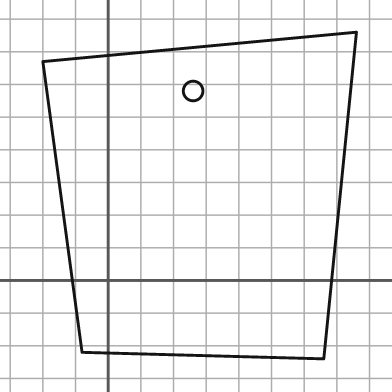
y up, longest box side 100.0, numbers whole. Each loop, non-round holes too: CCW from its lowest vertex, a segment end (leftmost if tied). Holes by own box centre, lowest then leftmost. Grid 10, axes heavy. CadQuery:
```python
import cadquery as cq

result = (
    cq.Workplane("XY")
    .moveTo(66.0, -24.0)
    .lineTo(76.0, 76.0)
    .lineTo(-20.0, 67.0)
    .lineTo(-8.0, -22.0)
    .close()
    .moveTo(26.0, 58.0)
    .circle(3.0)
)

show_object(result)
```